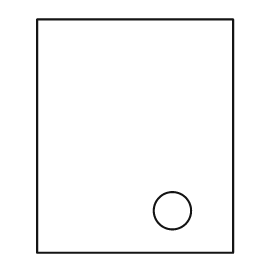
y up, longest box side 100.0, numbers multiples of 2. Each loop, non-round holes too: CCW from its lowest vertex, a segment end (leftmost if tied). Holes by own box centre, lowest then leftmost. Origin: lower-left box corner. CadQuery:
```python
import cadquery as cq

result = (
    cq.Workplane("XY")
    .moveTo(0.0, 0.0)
    .lineTo(84.0, 0.0)
    .lineTo(84.0, 100.0)
    .lineTo(0.0, 100.0)
    .close()
    .moveTo(58.0, 18.0)
    .circle(8.0)
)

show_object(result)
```